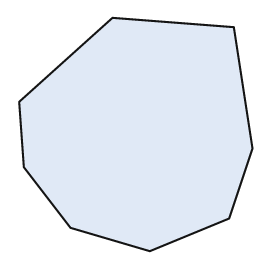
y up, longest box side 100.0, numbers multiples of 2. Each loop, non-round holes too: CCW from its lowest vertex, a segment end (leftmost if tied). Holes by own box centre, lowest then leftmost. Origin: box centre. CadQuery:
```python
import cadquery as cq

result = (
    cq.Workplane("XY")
    .moveTo(6.0, -50.0)
    .lineTo(40.0, -36.0)
    .lineTo(50.0, -6.0)
    .lineTo(42.0, 46.0)
    .lineTo(-10.0, 50.0)
    .lineTo(-50.0, 14.0)
    .lineTo(-48.0, -14.0)
    .lineTo(-28.0, -40.0)
    .close()
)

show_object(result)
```